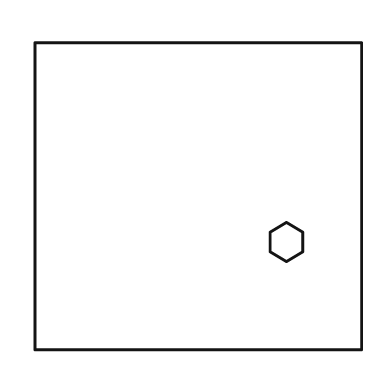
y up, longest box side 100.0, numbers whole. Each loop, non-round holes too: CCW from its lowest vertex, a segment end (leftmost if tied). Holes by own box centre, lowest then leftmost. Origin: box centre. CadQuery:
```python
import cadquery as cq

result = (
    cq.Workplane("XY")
    .moveTo(-50.0, -47.0)
    .lineTo(50.0, -47.0)
    .lineTo(50.0, 47.0)
    .lineTo(-50.0, 47.0)
    .close()
    .moveTo(27.0, -20.0)
    .lineTo(32.0, -17.0)
    .lineTo(32.0, -11.0)
    .lineTo(27.0, -8.0)
    .lineTo(22.0, -11.0)
    .lineTo(22.0, -17.0)
    .close()
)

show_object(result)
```